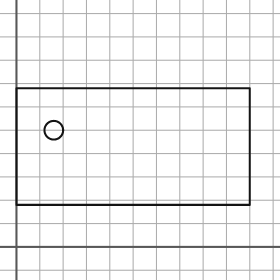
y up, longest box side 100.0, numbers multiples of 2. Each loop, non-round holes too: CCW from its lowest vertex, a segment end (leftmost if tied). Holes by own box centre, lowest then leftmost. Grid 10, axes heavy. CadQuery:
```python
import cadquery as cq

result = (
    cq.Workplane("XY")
    .moveTo(0.0, 18.0)
    .lineTo(100.0, 18.0)
    .lineTo(100.0, 68.0)
    .lineTo(0.0, 68.0)
    .close()
    .moveTo(16.0, 50.0)
    .circle(4.0)
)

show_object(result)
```